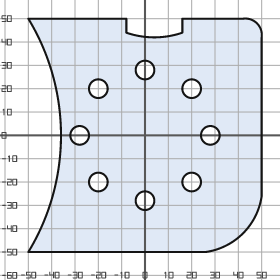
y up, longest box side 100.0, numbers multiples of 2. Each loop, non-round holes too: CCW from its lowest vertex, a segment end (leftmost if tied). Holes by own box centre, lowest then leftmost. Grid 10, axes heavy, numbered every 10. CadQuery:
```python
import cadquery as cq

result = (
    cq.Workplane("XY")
    .moveTo(-50.0, -50.0)
    .lineTo(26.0, -50.0)
    .threePointArc((42.0, -42.0), (50.0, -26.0))
    .lineTo(50.0, 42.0)
    .threePointArc((48.0, 48.0), (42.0, 50.0))
    .lineTo(16.0, 50.0)
    .lineTo(16.0, 44.0)
    .threePointArc((4.0, 42.0), (-8.0, 44.0))
    .lineTo(-8.0, 50.0)
    .lineTo(-50.0, 50.0)
    .threePointArc((-36.0, 0.0), (-50.0, -50.0))
    .close()
    .moveTo(0.0, -28.0)
    .circle(4.0)
    .moveTo(-20.0, -20.0)
    .circle(4.0)
    .moveTo(20.0, -20.0)
    .circle(4.0)
    .moveTo(-28.0, 0.0)
    .circle(4.0)
    .moveTo(28.0, 0.0)
    .circle(4.0)
    .moveTo(-20.0, 20.0)
    .circle(4.0)
    .moveTo(20.0, 20.0)
    .circle(4.0)
    .moveTo(0.0, 28.0)
    .circle(4.0)
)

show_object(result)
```